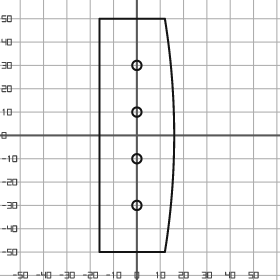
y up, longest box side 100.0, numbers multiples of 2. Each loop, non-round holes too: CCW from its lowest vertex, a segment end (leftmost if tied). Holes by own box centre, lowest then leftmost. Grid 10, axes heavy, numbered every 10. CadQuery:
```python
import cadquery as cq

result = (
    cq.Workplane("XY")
    .moveTo(-16.0, -50.0)
    .lineTo(12.0, -50.0)
    .threePointArc((16.0, 0.0), (12.0, 50.0))
    .lineTo(-16.0, 50.0)
    .close()
    .moveTo(0.0, -30.0)
    .circle(2.0)
    .moveTo(0.0, -10.0)
    .circle(2.0)
    .moveTo(0.0, 10.0)
    .circle(2.0)
    .moveTo(0.0, 30.0)
    .circle(2.0)
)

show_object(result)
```